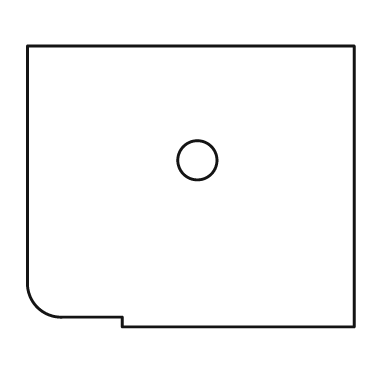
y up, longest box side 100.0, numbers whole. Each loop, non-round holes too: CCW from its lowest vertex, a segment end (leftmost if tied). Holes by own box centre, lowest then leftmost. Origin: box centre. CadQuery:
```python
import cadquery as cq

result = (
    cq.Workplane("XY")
    .moveTo(-21.0, -43.0)
    .lineTo(50.0, -43.0)
    .lineTo(50.0, 43.0)
    .lineTo(-50.0, 43.0)
    .lineTo(-50.0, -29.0)
    .threePointArc((-47.0, -37.0), (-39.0, -40.0))
    .lineTo(-21.0, -40.0)
    .close()
    .moveTo(2.0, 8.0)
    .circle(6.0)
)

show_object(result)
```